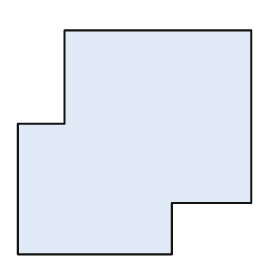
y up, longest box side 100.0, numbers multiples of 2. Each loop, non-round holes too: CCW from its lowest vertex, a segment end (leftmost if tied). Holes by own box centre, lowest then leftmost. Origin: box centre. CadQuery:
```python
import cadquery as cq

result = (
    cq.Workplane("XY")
    .moveTo(-50.0, -48.0)
    .lineTo(16.0, -48.0)
    .lineTo(16.0, -26.0)
    .lineTo(50.0, -26.0)
    .lineTo(50.0, 48.0)
    .lineTo(-30.0, 48.0)
    .lineTo(-30.0, 8.0)
    .lineTo(-50.0, 8.0)
    .close()
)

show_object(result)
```